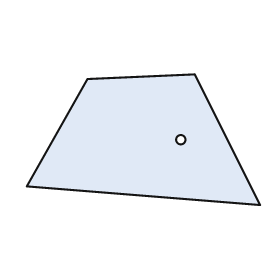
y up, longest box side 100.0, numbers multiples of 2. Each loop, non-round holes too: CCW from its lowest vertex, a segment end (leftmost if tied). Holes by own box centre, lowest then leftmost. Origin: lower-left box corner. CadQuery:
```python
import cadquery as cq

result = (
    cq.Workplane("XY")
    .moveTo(100.0, 0.0)
    .lineTo(72.0, 56.0)
    .lineTo(26.0, 54.0)
    .lineTo(0.0, 8.0)
    .close()
    .moveTo(66.0, 28.0)
    .circle(2.0)
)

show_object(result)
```